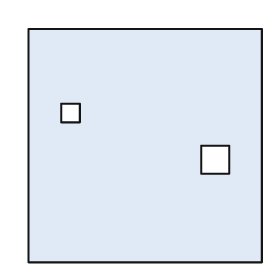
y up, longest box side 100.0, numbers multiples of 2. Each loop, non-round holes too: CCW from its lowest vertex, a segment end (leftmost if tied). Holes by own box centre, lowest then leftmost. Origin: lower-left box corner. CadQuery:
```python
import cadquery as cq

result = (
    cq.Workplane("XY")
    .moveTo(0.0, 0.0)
    .lineTo(100.0, 0.0)
    .lineTo(100.0, 100.0)
    .lineTo(0.0, 100.0)
    .close()
    .moveTo(74.0, 38.0)
    .lineTo(86.0, 38.0)
    .lineTo(86.0, 50.0)
    .lineTo(74.0, 50.0)
    .close()
    .moveTo(14.0, 60.0)
    .lineTo(22.0, 60.0)
    .lineTo(22.0, 68.0)
    .lineTo(14.0, 68.0)
    .close()
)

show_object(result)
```